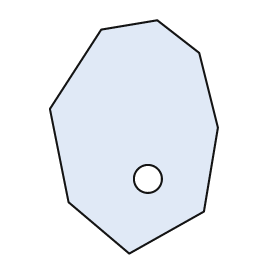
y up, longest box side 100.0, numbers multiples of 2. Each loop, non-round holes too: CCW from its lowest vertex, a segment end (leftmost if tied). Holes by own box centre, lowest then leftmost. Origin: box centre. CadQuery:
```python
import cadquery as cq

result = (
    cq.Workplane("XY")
    .moveTo(-2.0, -50.0)
    .lineTo(30.0, -32.0)
    .lineTo(36.0, 4.0)
    .lineTo(28.0, 36.0)
    .lineTo(10.0, 50.0)
    .lineTo(-14.0, 46.0)
    .lineTo(-36.0, 12.0)
    .lineTo(-28.0, -28.0)
    .close()
    .moveTo(6.0, -18.0)
    .circle(6.0)
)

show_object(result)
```